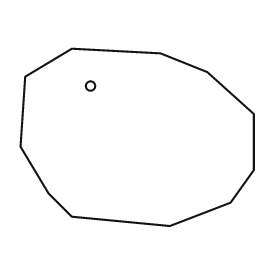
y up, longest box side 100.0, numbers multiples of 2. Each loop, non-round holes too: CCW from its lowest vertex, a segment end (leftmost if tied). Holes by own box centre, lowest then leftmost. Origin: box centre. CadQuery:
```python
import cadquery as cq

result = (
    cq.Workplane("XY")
    .moveTo(14.0, -38.0)
    .lineTo(40.0, -28.0)
    .lineTo(50.0, -14.0)
    .lineTo(50.0, 10.0)
    .lineTo(30.0, 28.0)
    .lineTo(10.0, 36.0)
    .lineTo(-28.0, 38.0)
    .lineTo(-48.0, 26.0)
    .lineTo(-50.0, -4.0)
    .lineTo(-38.0, -24.0)
    .lineTo(-28.0, -34.0)
    .close()
    .moveTo(-20.0, 22.0)
    .circle(2.0)
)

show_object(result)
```